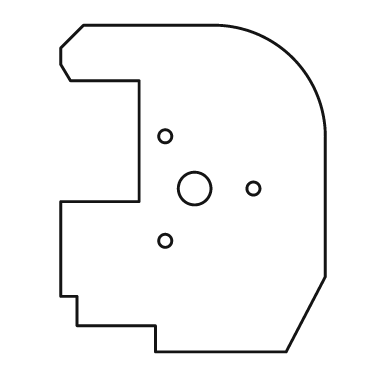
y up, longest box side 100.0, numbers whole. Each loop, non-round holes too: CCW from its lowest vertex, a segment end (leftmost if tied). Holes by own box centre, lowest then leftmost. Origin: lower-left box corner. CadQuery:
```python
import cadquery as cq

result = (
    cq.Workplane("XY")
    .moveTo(29.0, 0.0)
    .lineTo(69.0, 0.0)
    .lineTo(81.0, 23.0)
    .lineTo(81.0, 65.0)
    .threePointArc((71.0, 90.0), (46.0, 100.0))
    .lineTo(7.0, 100.0)
    .lineTo(0.0, 93.0)
    .lineTo(0.0, 88.0)
    .lineTo(3.0, 83.0)
    .lineTo(24.0, 83.0)
    .lineTo(24.0, 46.0)
    .lineTo(0.0, 46.0)
    .lineTo(0.0, 17.0)
    .lineTo(5.0, 17.0)
    .lineTo(5.0, 8.0)
    .lineTo(29.0, 8.0)
    .close()
    .moveTo(32.0, 34.0)
    .circle(2.0)
    .moveTo(41.0, 50.0)
    .circle(5.0)
    .moveTo(59.0, 50.0)
    .circle(2.0)
    .moveTo(32.0, 66.0)
    .circle(2.0)
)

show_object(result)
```